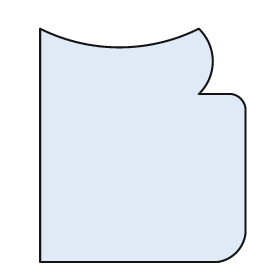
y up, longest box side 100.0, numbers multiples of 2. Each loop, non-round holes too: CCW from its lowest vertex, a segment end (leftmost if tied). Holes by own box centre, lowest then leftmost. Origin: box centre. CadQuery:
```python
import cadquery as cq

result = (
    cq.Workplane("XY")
    .moveTo(-44.0, -50.0)
    .lineTo(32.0, -50.0)
    .threePointArc((40.0, -46.0), (44.0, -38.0))
    .lineTo(44.0, 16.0)
    .threePointArc((42.0, 20.0), (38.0, 22.0))
    .lineTo(24.0, 22.0)
    .threePointArc((30.0, 36.0), (24.0, 50.0))
    .threePointArc((-10.0, 42.0), (-44.0, 50.0))
    .close()
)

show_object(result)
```